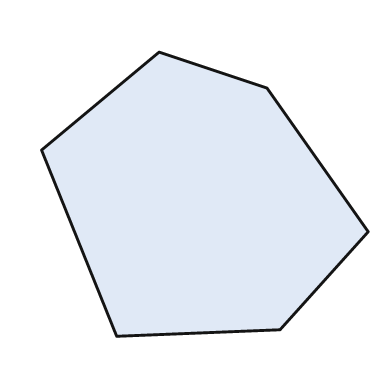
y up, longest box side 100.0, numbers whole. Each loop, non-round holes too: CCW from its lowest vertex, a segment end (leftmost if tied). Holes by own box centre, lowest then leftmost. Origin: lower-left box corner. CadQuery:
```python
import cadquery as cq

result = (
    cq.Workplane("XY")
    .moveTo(23.0, 0.0)
    .lineTo(73.0, 2.0)
    .lineTo(100.0, 32.0)
    .lineTo(69.0, 76.0)
    .lineTo(36.0, 87.0)
    .lineTo(0.0, 57.0)
    .close()
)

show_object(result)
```